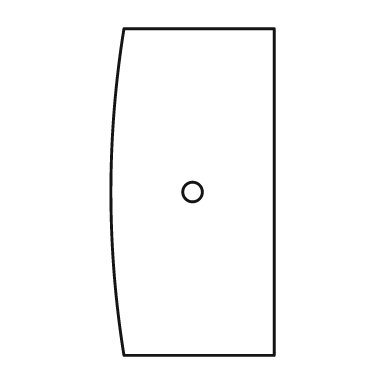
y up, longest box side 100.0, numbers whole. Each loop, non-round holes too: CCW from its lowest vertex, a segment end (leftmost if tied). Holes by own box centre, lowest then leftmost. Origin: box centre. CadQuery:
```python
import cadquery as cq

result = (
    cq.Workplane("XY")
    .moveTo(-21.0, -50.0)
    .lineTo(25.0, -50.0)
    .lineTo(25.0, 50.0)
    .lineTo(-21.0, 50.0)
    .threePointArc((-25.0, 0.0), (-21.0, -50.0))
    .close()
    .moveTo(0.0, 0.0)
    .circle(3.0)
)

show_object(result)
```